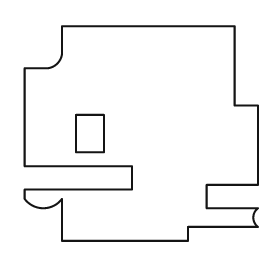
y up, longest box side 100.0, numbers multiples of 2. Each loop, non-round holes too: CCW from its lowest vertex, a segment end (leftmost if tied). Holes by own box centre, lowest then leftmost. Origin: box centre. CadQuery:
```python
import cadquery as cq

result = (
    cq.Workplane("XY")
    .moveTo(-34.0, -46.0)
    .lineTo(20.0, -46.0)
    .lineTo(20.0, -40.0)
    .lineTo(50.0, -40.0)
    .threePointArc((48.0, -36.0), (50.0, -32.0))
    .lineTo(28.0, -32.0)
    .lineTo(28.0, -22.0)
    .lineTo(50.0, -22.0)
    .lineTo(50.0, 12.0)
    .lineTo(40.0, 12.0)
    .lineTo(40.0, 46.0)
    .lineTo(-34.0, 46.0)
    .lineTo(-34.0, 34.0)
    .threePointArc((-36.0, 30.0), (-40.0, 28.0))
    .lineTo(-50.0, 28.0)
    .lineTo(-50.0, -14.0)
    .lineTo(-4.0, -14.0)
    .lineTo(-4.0, -24.0)
    .lineTo(-50.0, -24.0)
    .lineTo(-50.0, -28.0)
    .threePointArc((-42.0, -32.0), (-34.0, -28.0))
    .close()
    .moveTo(-28.0, -8.0)
    .lineTo(-16.0, -8.0)
    .lineTo(-16.0, 8.0)
    .lineTo(-28.0, 8.0)
    .close()
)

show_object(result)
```